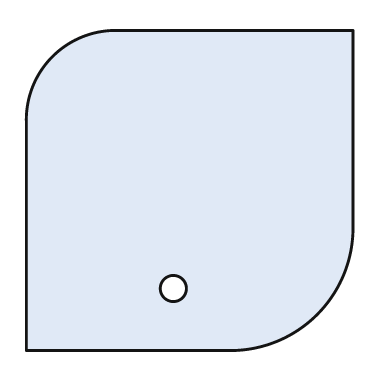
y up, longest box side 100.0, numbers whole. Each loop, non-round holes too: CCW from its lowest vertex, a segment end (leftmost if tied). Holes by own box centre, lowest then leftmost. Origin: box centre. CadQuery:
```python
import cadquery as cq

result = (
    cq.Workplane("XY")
    .moveTo(-50.0, -49.0)
    .lineTo(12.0, -49.0)
    .threePointArc((39.0, -38.0), (50.0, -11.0))
    .lineTo(50.0, 49.0)
    .lineTo(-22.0, 49.0)
    .threePointArc((-42.0, 41.0), (-50.0, 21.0))
    .close()
    .moveTo(-5.0, -30.0)
    .circle(4.0)
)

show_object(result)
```